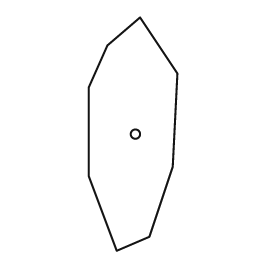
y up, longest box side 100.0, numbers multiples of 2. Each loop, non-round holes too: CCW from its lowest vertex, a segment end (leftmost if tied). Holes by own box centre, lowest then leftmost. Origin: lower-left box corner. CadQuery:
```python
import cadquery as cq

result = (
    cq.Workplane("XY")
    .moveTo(12.0, 0.0)
    .lineTo(26.0, 6.0)
    .lineTo(36.0, 36.0)
    .lineTo(38.0, 76.0)
    .lineTo(22.0, 100.0)
    .lineTo(8.0, 88.0)
    .lineTo(0.0, 70.0)
    .lineTo(0.0, 32.0)
    .close()
    .moveTo(20.0, 50.0)
    .circle(2.0)
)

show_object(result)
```